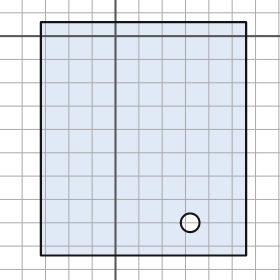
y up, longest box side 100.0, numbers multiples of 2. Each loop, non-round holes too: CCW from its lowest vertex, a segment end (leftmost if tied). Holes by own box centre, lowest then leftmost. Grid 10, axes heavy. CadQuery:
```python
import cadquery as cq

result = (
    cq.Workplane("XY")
    .moveTo(-32.0, -94.0)
    .lineTo(56.0, -94.0)
    .lineTo(56.0, 6.0)
    .lineTo(-32.0, 6.0)
    .close()
    .moveTo(32.0, -80.0)
    .circle(4.0)
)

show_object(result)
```